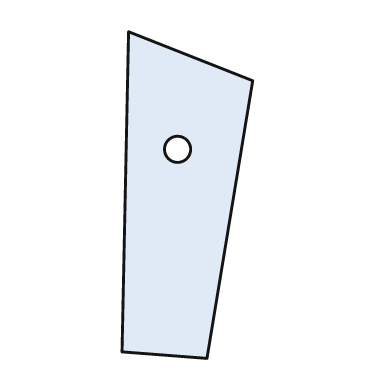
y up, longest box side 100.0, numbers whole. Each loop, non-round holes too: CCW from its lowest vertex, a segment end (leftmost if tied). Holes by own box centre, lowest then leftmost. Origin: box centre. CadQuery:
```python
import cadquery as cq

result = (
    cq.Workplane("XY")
    .moveTo(6.0, -50.0)
    .lineTo(20.0, 35.0)
    .lineTo(-18.0, 50.0)
    .lineTo(-20.0, -48.0)
    .close()
    .moveTo(-3.0, 14.0)
    .circle(4.0)
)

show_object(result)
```